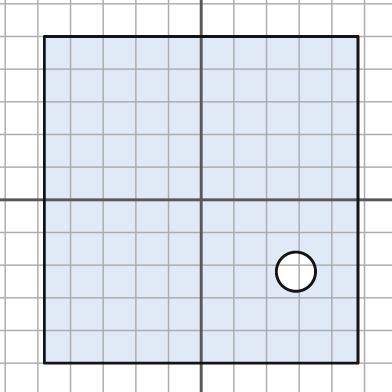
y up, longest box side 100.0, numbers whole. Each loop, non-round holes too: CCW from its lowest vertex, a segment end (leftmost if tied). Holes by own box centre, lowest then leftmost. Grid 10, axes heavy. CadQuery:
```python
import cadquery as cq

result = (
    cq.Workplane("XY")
    .moveTo(-48.0, -50.0)
    .lineTo(48.0, -50.0)
    .lineTo(48.0, 50.0)
    .lineTo(-48.0, 50.0)
    .close()
    .moveTo(29.0, -22.0)
    .circle(6.0)
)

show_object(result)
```